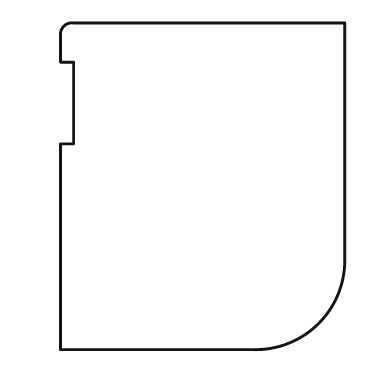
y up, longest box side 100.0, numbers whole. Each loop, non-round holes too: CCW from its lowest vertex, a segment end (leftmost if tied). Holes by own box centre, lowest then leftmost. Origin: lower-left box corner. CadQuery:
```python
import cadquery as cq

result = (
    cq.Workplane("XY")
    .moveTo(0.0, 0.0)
    .lineTo(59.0, 0.0)
    .threePointArc((79.0, 8.0), (87.0, 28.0))
    .lineTo(87.0, 100.0)
    .lineTo(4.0, 100.0)
    .threePointArc((1.0, 99.0), (0.0, 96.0))
    .lineTo(0.0, 88.0)
    .lineTo(4.0, 88.0)
    .lineTo(4.0, 63.0)
    .lineTo(0.0, 63.0)
    .close()
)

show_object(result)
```